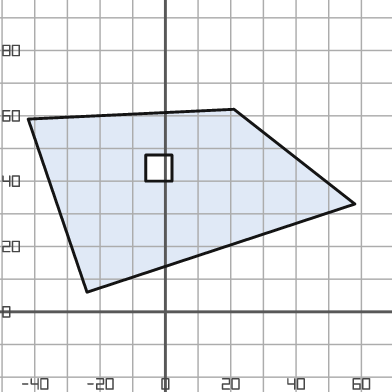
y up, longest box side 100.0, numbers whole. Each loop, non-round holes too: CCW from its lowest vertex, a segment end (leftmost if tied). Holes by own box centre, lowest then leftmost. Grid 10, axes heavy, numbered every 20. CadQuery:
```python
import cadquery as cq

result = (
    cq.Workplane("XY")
    .moveTo(-24.0, 6.0)
    .lineTo(58.0, 33.0)
    .lineTo(21.0, 62.0)
    .lineTo(-42.0, 59.0)
    .close()
    .moveTo(-6.0, 40.0)
    .lineTo(2.0, 40.0)
    .lineTo(2.0, 48.0)
    .lineTo(-6.0, 48.0)
    .close()
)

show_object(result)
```